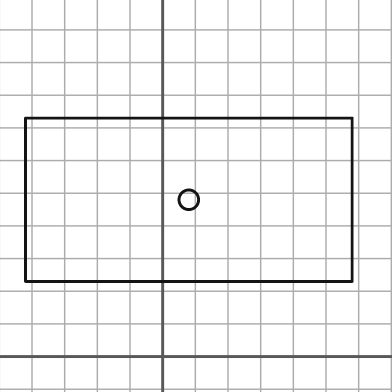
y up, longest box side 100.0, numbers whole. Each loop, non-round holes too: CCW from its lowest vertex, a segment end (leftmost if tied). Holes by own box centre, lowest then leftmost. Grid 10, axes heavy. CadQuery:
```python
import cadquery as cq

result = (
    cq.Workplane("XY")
    .moveTo(-42.0, 23.0)
    .lineTo(58.0, 23.0)
    .lineTo(58.0, 73.0)
    .lineTo(-42.0, 73.0)
    .close()
    .moveTo(8.0, 48.0)
    .circle(3.0)
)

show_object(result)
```